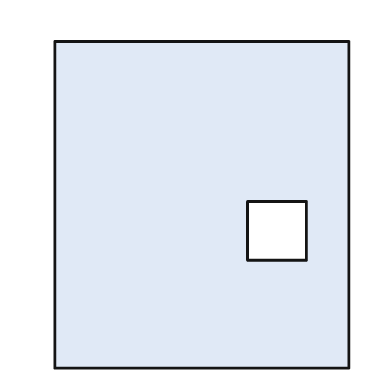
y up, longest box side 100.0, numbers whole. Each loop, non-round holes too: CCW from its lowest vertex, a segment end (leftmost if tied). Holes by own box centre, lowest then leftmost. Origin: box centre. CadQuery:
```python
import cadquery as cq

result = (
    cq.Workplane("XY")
    .moveTo(-45.0, -50.0)
    .lineTo(45.0, -50.0)
    .lineTo(45.0, 50.0)
    .lineTo(-45.0, 50.0)
    .close()
    .moveTo(14.0, -17.0)
    .lineTo(32.0, -17.0)
    .lineTo(32.0, 1.0)
    .lineTo(14.0, 1.0)
    .close()
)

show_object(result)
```